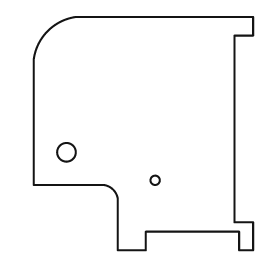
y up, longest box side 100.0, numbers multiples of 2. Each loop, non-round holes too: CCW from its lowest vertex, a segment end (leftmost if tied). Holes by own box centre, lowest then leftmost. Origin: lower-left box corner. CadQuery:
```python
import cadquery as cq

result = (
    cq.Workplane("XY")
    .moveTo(36.0, 0.0)
    .lineTo(48.0, 0.0)
    .lineTo(48.0, 8.0)
    .lineTo(88.0, 8.0)
    .lineTo(88.0, 0.0)
    .lineTo(94.0, 0.0)
    .lineTo(94.0, 12.0)
    .lineTo(86.0, 12.0)
    .lineTo(86.0, 92.0)
    .lineTo(94.0, 92.0)
    .lineTo(94.0, 100.0)
    .lineTo(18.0, 100.0)
    .threePointArc((6.0, 94.0), (0.0, 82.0))
    .lineTo(0.0, 28.0)
    .lineTo(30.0, 28.0)
    .threePointArc((34.0, 26.0), (36.0, 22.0))
    .close()
    .moveTo(52.0, 30.0)
    .circle(2.0)
    .moveTo(14.0, 42.0)
    .circle(4.0)
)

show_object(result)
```